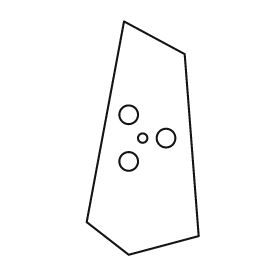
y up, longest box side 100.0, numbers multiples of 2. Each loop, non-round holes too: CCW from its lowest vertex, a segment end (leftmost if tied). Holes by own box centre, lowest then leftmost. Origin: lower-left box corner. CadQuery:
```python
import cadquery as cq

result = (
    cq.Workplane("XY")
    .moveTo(18.0, 0.0)
    .lineTo(48.0, 8.0)
    .lineTo(42.0, 86.0)
    .lineTo(16.0, 100.0)
    .lineTo(0.0, 14.0)
    .close()
    .moveTo(18.0, 40.0)
    .circle(4.0)
    .moveTo(24.0, 50.0)
    .circle(2.0)
    .moveTo(34.0, 50.0)
    .circle(4.0)
    .moveTo(18.0, 60.0)
    .circle(4.0)
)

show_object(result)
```